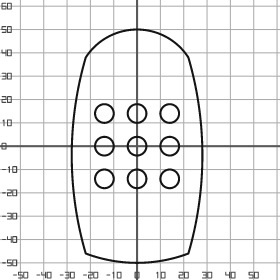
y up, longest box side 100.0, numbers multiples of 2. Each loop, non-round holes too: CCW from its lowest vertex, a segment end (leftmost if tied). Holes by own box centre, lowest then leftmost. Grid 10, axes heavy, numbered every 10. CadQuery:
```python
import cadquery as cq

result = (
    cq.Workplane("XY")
    .moveTo(-22.0, -46.0)
    .threePointArc((0.0, -50.0), (22.0, -46.0))
    .threePointArc((28.0, -4.0), (22.0, 38.0))
    .threePointArc((0.0, 50.0), (-22.0, 38.0))
    .threePointArc((-28.0, -4.0), (-22.0, -46.0))
    .close()
    .moveTo(-14.0, -14.0)
    .circle(4.0)
    .moveTo(0.0, -14.0)
    .circle(4.0)
    .moveTo(14.0, -14.0)
    .circle(4.0)
    .moveTo(-14.0, 0.0)
    .circle(4.0)
    .moveTo(0.0, 0.0)
    .circle(4.0)
    .moveTo(14.0, 0.0)
    .circle(4.0)
    .moveTo(-14.0, 14.0)
    .circle(4.0)
    .moveTo(0.0, 14.0)
    .circle(4.0)
    .moveTo(14.0, 14.0)
    .circle(4.0)
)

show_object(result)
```